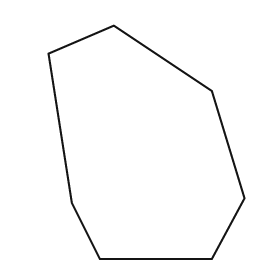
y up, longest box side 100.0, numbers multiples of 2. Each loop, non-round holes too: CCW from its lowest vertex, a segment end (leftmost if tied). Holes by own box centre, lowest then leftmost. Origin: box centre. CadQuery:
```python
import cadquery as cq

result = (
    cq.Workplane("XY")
    .moveTo(-20.0, -50.0)
    .lineTo(28.0, -50.0)
    .lineTo(42.0, -24.0)
    .lineTo(28.0, 22.0)
    .lineTo(-14.0, 50.0)
    .lineTo(-42.0, 38.0)
    .lineTo(-32.0, -26.0)
    .close()
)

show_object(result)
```